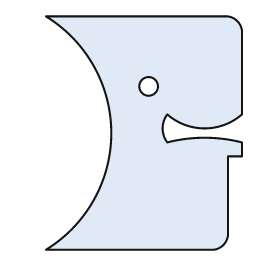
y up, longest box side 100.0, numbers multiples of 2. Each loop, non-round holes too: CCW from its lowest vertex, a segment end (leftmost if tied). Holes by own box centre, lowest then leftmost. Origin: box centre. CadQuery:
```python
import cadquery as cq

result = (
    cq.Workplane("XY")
    .moveTo(-42.0, -50.0)
    .lineTo(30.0, -50.0)
    .threePointArc((34.0, -48.0), (36.0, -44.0))
    .lineTo(36.0, -10.0)
    .lineTo(42.0, -10.0)
    .lineTo(42.0, -4.0)
    .threePointArc((26.0, -2.0), (10.0, -4.0))
    .threePointArc((8.0, 2.0), (10.0, 8.0))
    .threePointArc((26.0, 2.0), (42.0, 8.0))
    .lineTo(42.0, 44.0)
    .threePointArc((40.0, 48.0), (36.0, 50.0))
    .lineTo(-42.0, 50.0)
    .threePointArc((-14.0, 0.0), (-42.0, -50.0))
    .close()
    .moveTo(2.0, 20.0)
    .circle(4.0)
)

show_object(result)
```